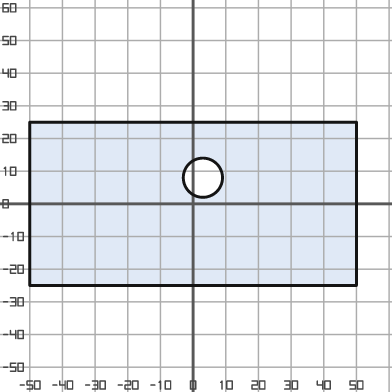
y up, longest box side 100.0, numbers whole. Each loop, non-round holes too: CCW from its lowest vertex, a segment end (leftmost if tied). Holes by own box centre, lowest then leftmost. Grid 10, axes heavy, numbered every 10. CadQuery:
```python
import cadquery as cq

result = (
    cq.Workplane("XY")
    .moveTo(-50.0, -25.0)
    .lineTo(50.0, -25.0)
    .lineTo(50.0, 25.0)
    .lineTo(-50.0, 25.0)
    .close()
    .moveTo(3.0, 8.0)
    .circle(6.0)
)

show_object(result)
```